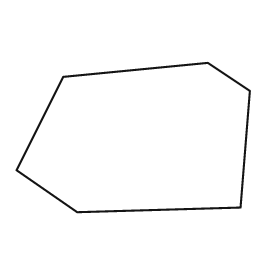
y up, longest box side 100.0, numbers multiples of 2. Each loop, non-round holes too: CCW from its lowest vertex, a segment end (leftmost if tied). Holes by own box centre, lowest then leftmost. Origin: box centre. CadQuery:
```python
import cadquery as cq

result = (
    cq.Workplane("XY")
    .moveTo(-24.0, -32.0)
    .lineTo(46.0, -30.0)
    .lineTo(50.0, 20.0)
    .lineTo(32.0, 32.0)
    .lineTo(-30.0, 26.0)
    .lineTo(-50.0, -14.0)
    .close()
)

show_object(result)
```